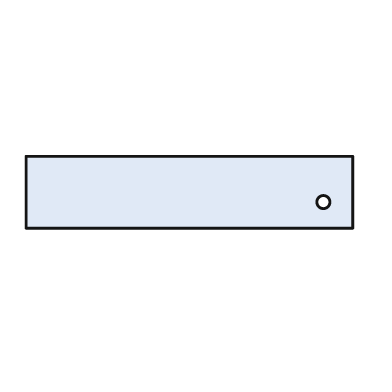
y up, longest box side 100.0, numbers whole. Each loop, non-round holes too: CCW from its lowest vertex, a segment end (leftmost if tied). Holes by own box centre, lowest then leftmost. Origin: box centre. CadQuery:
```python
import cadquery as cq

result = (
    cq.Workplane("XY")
    .moveTo(-50.0, -11.0)
    .lineTo(50.0, -11.0)
    .lineTo(50.0, 11.0)
    .lineTo(-50.0, 11.0)
    .close()
    .moveTo(41.0, -3.0)
    .circle(2.0)
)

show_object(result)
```